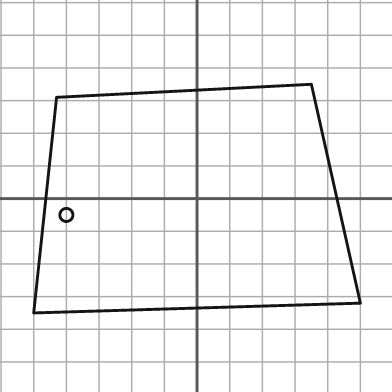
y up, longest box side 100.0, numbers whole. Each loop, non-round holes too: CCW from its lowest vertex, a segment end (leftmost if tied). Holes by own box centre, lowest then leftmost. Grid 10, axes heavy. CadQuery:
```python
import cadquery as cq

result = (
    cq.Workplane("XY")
    .moveTo(-50.0, -35.0)
    .lineTo(50.0, -32.0)
    .lineTo(35.0, 35.0)
    .lineTo(-43.0, 31.0)
    .close()
    .moveTo(-40.0, -5.0)
    .circle(2.0)
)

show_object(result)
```